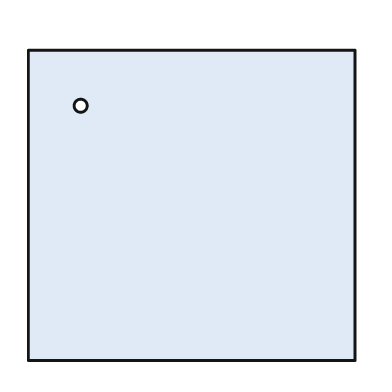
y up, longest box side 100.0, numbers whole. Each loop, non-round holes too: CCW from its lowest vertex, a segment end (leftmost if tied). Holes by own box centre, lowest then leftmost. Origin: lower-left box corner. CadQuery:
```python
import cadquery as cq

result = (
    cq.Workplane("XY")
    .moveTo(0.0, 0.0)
    .lineTo(100.0, 0.0)
    .lineTo(100.0, 95.0)
    .lineTo(0.0, 95.0)
    .close()
    .moveTo(16.0, 78.0)
    .circle(2.0)
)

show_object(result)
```